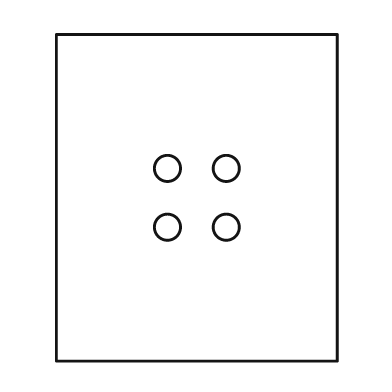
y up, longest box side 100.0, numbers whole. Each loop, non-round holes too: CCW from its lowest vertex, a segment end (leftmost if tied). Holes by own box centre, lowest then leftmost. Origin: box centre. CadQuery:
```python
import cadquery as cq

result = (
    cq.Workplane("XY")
    .moveTo(-43.0, -50.0)
    .lineTo(43.0, -50.0)
    .lineTo(43.0, 50.0)
    .lineTo(-43.0, 50.0)
    .close()
    .moveTo(-9.0, -9.0)
    .circle(4.0)
    .moveTo(9.0, -9.0)
    .circle(4.0)
    .moveTo(-9.0, 9.0)
    .circle(4.0)
    .moveTo(9.0, 9.0)
    .circle(4.0)
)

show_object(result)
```